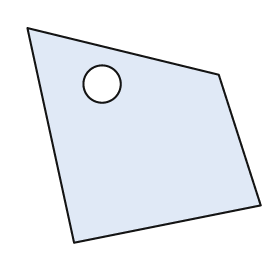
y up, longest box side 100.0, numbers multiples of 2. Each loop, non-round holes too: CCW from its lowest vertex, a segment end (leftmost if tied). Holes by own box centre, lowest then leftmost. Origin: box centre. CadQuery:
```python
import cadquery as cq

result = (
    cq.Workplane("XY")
    .moveTo(-30.0, -46.0)
    .lineTo(50.0, -30.0)
    .lineTo(32.0, 26.0)
    .lineTo(-50.0, 46.0)
    .close()
    .moveTo(-18.0, 22.0)
    .circle(8.0)
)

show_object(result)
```